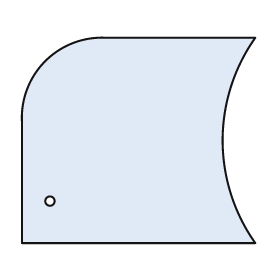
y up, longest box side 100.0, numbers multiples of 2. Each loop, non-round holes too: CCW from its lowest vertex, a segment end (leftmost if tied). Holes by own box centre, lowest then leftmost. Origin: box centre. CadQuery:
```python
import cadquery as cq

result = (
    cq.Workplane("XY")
    .moveTo(-50.0, -44.0)
    .lineTo(50.0, -44.0)
    .threePointArc((36.0, 0.0), (50.0, 44.0))
    .lineTo(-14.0, 44.0)
    .threePointArc((-40.0, 34.0), (-50.0, 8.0))
    .close()
    .moveTo(-38.0, -26.0)
    .circle(2.0)
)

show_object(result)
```